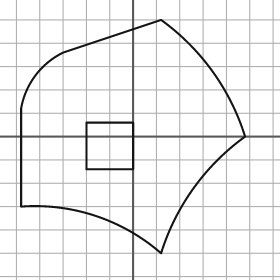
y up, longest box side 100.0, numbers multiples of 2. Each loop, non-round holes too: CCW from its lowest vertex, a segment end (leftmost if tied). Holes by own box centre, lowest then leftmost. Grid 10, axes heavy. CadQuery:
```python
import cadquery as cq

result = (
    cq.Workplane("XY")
    .moveTo(12.0, -50.0)
    .threePointArc((26.0, -22.0), (48.0, 0.0))
    .threePointArc((34.0, 28.0), (12.0, 50.0))
    .lineTo(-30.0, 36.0)
    .threePointArc((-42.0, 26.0), (-48.0, 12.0))
    .lineTo(-48.0, -30.0)
    .threePointArc((-16.0, -34.0), (12.0, -50.0))
    .close()
    .moveTo(-20.0, -14.0)
    .lineTo(0.0, -14.0)
    .lineTo(0.0, 6.0)
    .lineTo(-20.0, 6.0)
    .close()
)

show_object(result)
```